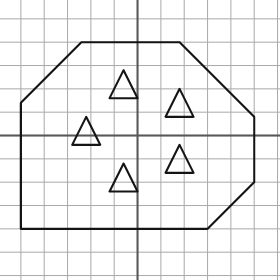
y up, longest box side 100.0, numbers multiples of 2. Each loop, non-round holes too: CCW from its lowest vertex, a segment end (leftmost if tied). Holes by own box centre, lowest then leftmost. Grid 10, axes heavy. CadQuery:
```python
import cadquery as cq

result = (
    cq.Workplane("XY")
    .moveTo(-50.0, -40.0)
    .lineTo(30.0, -40.0)
    .lineTo(50.0, -20.0)
    .lineTo(50.0, 8.0)
    .lineTo(18.0, 40.0)
    .lineTo(-24.0, 40.0)
    .lineTo(-50.0, 14.0)
    .close()
    .moveTo(-12.0, -24.0)
    .lineTo(0.0, -24.0)
    .lineTo(-6.0, -12.0)
    .close()
    .moveTo(12.0, -16.0)
    .lineTo(24.0, -16.0)
    .lineTo(18.0, -4.0)
    .close()
    .moveTo(-28.0, -4.0)
    .lineTo(-16.0, -4.0)
    .lineTo(-22.0, 8.0)
    .close()
    .moveTo(12.0, 8.0)
    .lineTo(24.0, 8.0)
    .lineTo(18.0, 20.0)
    .close()
    .moveTo(-12.0, 16.0)
    .lineTo(0.0, 16.0)
    .lineTo(-6.0, 28.0)
    .close()
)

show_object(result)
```